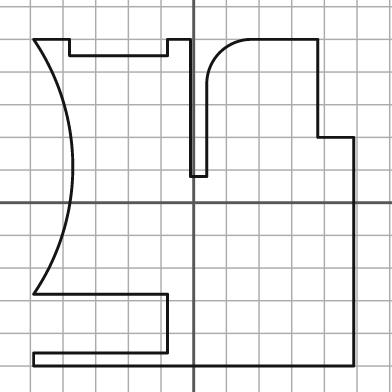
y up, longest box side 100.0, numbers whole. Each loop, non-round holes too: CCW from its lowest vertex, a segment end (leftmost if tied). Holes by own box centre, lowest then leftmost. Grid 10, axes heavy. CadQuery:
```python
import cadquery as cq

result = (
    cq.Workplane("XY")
    .moveTo(-49.0, -50.0)
    .lineTo(49.0, -50.0)
    .lineTo(49.0, 20.0)
    .lineTo(38.0, 20.0)
    .lineTo(38.0, 50.0)
    .lineTo(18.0, 50.0)
    .threePointArc((8.0, 46.0), (4.0, 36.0))
    .lineTo(4.0, 8.0)
    .lineTo(-1.0, 8.0)
    .lineTo(-1.0, 50.0)
    .lineTo(-8.0, 50.0)
    .lineTo(-8.0, 45.0)
    .lineTo(-38.0, 45.0)
    .lineTo(-38.0, 50.0)
    .lineTo(-49.0, 50.0)
    .threePointArc((-37.0, 11.0), (-49.0, -28.0))
    .lineTo(-8.0, -28.0)
    .lineTo(-8.0, -46.0)
    .lineTo(-49.0, -46.0)
    .close()
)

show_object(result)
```